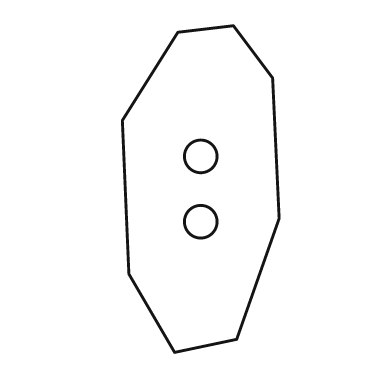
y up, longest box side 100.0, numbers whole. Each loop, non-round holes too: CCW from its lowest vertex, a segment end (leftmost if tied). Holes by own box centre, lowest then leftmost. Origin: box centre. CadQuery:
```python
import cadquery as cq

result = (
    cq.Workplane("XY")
    .moveTo(-8.0, -50.0)
    .lineTo(11.0, -46.0)
    .lineTo(24.0, -9.0)
    .lineTo(22.0, 34.0)
    .lineTo(10.0, 50.0)
    .lineTo(-7.0, 48.0)
    .lineTo(-24.0, 21.0)
    .lineTo(-22.0, -26.0)
    .close()
    .moveTo(0.0, -10.0)
    .circle(5.0)
    .moveTo(0.0, 10.0)
    .circle(5.0)
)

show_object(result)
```